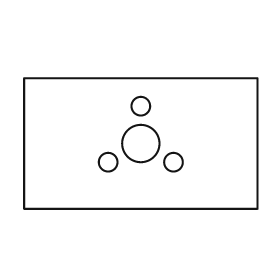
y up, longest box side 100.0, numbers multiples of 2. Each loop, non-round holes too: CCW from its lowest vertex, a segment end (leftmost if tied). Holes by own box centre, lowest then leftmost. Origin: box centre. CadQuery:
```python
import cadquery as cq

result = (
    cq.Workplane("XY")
    .moveTo(-50.0, -28.0)
    .lineTo(50.0, -28.0)
    .lineTo(50.0, 28.0)
    .lineTo(-50.0, 28.0)
    .close()
    .moveTo(-14.0, -8.0)
    .circle(4.0)
    .moveTo(14.0, -8.0)
    .circle(4.0)
    .moveTo(0.0, 0.0)
    .circle(8.0)
    .moveTo(0.0, 16.0)
    .circle(4.0)
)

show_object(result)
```